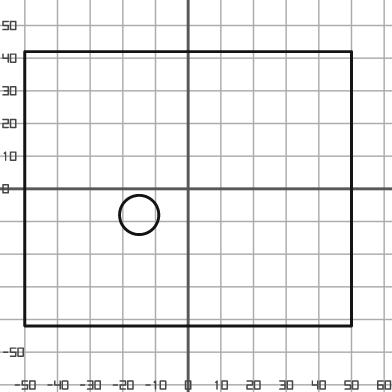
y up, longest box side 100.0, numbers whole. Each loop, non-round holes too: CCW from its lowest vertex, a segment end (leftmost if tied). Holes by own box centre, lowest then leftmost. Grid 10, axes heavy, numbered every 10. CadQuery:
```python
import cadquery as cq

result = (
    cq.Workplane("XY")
    .moveTo(-50.0, -42.0)
    .lineTo(50.0, -42.0)
    .lineTo(50.0, 42.0)
    .lineTo(-50.0, 42.0)
    .close()
    .moveTo(-15.0, -8.0)
    .circle(6.0)
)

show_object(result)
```